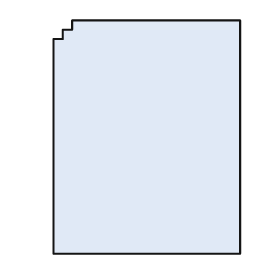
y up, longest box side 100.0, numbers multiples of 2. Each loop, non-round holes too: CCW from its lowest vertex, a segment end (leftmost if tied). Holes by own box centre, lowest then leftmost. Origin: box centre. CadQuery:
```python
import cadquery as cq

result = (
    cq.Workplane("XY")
    .moveTo(-40.0, -50.0)
    .lineTo(40.0, -50.0)
    .lineTo(40.0, 50.0)
    .lineTo(-32.0, 50.0)
    .lineTo(-32.0, 46.0)
    .lineTo(-36.0, 46.0)
    .lineTo(-36.0, 42.0)
    .lineTo(-40.0, 42.0)
    .close()
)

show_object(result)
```